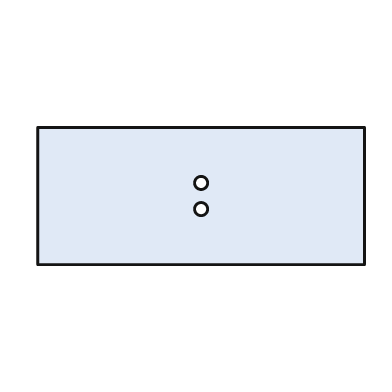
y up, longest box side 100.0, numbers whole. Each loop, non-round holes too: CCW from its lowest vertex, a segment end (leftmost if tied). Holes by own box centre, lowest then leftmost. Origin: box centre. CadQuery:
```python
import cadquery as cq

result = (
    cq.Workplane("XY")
    .moveTo(-50.0, -21.0)
    .lineTo(50.0, -21.0)
    .lineTo(50.0, 21.0)
    .lineTo(-50.0, 21.0)
    .close()
    .moveTo(0.0, -4.0)
    .circle(2.0)
    .moveTo(0.0, 4.0)
    .circle(2.0)
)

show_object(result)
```